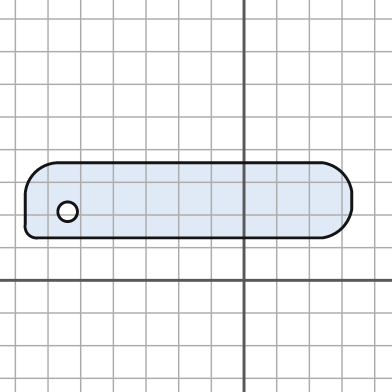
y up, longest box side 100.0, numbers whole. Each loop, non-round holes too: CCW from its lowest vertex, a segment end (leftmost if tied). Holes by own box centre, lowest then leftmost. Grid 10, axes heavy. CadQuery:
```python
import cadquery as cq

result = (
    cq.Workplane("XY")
    .moveTo(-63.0, 13.0)
    .lineTo(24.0, 13.0)
    .threePointArc((30.0, 16.0), (33.0, 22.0))
    .lineTo(33.0, 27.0)
    .threePointArc((30.0, 33.0), (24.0, 36.0))
    .lineTo(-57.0, 36.0)
    .threePointArc((-64.0, 33.0), (-67.0, 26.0))
    .lineTo(-67.0, 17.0)
    .threePointArc((-66.0, 14.0), (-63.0, 13.0))
    .close()
    .moveTo(-54.0, 21.0)
    .circle(3.0)
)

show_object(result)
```